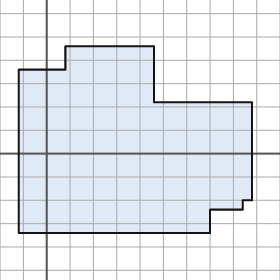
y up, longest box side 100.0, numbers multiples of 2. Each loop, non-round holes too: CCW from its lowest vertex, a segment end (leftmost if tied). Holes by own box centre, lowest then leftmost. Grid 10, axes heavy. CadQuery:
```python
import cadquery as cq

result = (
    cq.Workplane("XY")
    .moveTo(-12.0, -34.0)
    .lineTo(70.0, -34.0)
    .lineTo(70.0, -24.0)
    .lineTo(84.0, -24.0)
    .lineTo(84.0, -20.0)
    .lineTo(88.0, -20.0)
    .lineTo(88.0, 22.0)
    .lineTo(46.0, 22.0)
    .lineTo(46.0, 46.0)
    .lineTo(8.0, 46.0)
    .lineTo(8.0, 36.0)
    .lineTo(-12.0, 36.0)
    .close()
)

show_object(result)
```